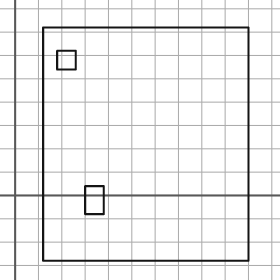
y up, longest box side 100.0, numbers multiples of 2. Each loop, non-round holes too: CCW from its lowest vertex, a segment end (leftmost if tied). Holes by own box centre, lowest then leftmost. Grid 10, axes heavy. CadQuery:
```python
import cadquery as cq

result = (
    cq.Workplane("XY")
    .moveTo(12.0, -28.0)
    .lineTo(100.0, -28.0)
    .lineTo(100.0, 72.0)
    .lineTo(12.0, 72.0)
    .close()
    .moveTo(30.0, -8.0)
    .lineTo(38.0, -8.0)
    .lineTo(38.0, 4.0)
    .lineTo(30.0, 4.0)
    .close()
    .moveTo(18.0, 54.0)
    .lineTo(26.0, 54.0)
    .lineTo(26.0, 62.0)
    .lineTo(18.0, 62.0)
    .close()
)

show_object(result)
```